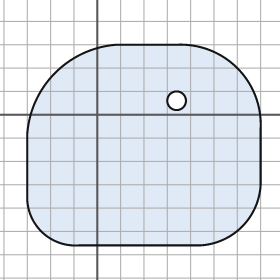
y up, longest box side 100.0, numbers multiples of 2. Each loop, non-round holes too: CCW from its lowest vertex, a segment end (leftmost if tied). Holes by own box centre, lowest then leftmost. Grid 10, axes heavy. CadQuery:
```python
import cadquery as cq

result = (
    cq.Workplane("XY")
    .moveTo(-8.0, -56.0)
    .lineTo(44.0, -56.0)
    .threePointArc((62.0, -48.0), (70.0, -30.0))
    .lineTo(70.0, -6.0)
    .threePointArc((60.0, 20.0), (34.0, 30.0))
    .lineTo(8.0, 30.0)
    .threePointArc((-18.0, 18.0), (-30.0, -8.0))
    .lineTo(-30.0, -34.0)
    .threePointArc((-24.0, -50.0), (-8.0, -56.0))
    .close()
    .moveTo(34.0, 6.0)
    .circle(4.0)
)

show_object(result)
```